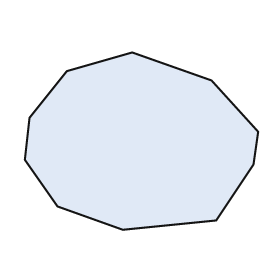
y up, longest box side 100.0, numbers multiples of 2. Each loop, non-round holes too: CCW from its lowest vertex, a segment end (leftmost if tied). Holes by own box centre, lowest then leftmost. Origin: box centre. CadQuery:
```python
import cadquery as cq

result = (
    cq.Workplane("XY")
    .moveTo(-8.0, -38.0)
    .lineTo(32.0, -34.0)
    .lineTo(48.0, -10.0)
    .lineTo(50.0, 4.0)
    .lineTo(30.0, 26.0)
    .lineTo(-4.0, 38.0)
    .lineTo(-32.0, 30.0)
    .lineTo(-48.0, 10.0)
    .lineTo(-50.0, -8.0)
    .lineTo(-36.0, -28.0)
    .close()
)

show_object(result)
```